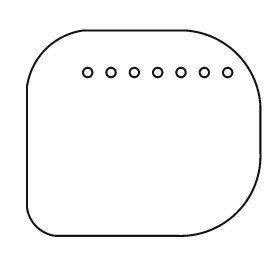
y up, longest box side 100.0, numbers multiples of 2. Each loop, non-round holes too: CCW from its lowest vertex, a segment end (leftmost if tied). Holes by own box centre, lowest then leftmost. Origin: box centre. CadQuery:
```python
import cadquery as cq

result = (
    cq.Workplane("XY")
    .moveTo(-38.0, -44.0)
    .lineTo(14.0, -44.0)
    .threePointArc((40.0, -34.0), (50.0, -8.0))
    .lineTo(50.0, 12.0)
    .threePointArc((40.0, 34.0), (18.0, 44.0))
    .lineTo(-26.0, 44.0)
    .threePointArc((-42.0, 36.0), (-50.0, 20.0))
    .lineTo(-50.0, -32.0)
    .threePointArc((-46.0, -40.0), (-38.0, -44.0))
    .close()
    .moveTo(-24.0, 26.0)
    .circle(2.0)
    .moveTo(-14.0, 26.0)
    .circle(2.0)
    .moveTo(-4.0, 26.0)
    .circle(2.0)
    .moveTo(6.0, 26.0)
    .circle(2.0)
    .moveTo(16.0, 26.0)
    .circle(2.0)
    .moveTo(26.0, 26.0)
    .circle(2.0)
    .moveTo(36.0, 26.0)
    .circle(2.0)
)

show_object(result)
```